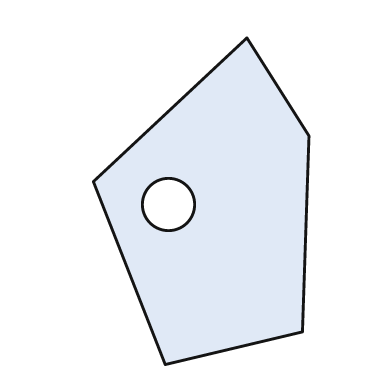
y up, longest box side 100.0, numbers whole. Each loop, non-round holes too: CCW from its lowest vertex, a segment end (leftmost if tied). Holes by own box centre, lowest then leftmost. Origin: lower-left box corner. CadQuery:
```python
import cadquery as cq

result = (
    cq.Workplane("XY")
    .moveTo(22.0, 0.0)
    .lineTo(64.0, 10.0)
    .lineTo(66.0, 70.0)
    .lineTo(47.0, 100.0)
    .lineTo(0.0, 56.0)
    .close()
    .moveTo(23.0, 49.0)
    .circle(8.0)
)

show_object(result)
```